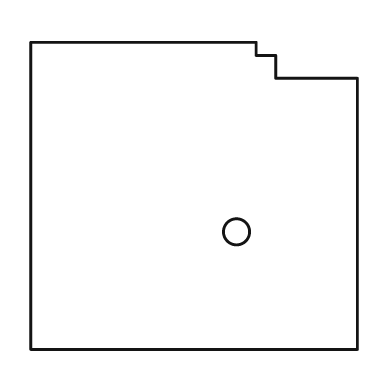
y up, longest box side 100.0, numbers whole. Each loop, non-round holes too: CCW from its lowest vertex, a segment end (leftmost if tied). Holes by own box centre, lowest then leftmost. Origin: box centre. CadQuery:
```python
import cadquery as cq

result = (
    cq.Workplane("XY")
    .moveTo(-50.0, -47.0)
    .lineTo(50.0, -47.0)
    .lineTo(50.0, 36.0)
    .lineTo(25.0, 36.0)
    .lineTo(25.0, 43.0)
    .lineTo(19.0, 43.0)
    .lineTo(19.0, 47.0)
    .lineTo(-50.0, 47.0)
    .close()
    .moveTo(13.0, -11.0)
    .circle(4.0)
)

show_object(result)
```